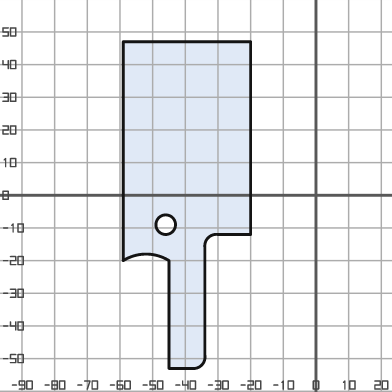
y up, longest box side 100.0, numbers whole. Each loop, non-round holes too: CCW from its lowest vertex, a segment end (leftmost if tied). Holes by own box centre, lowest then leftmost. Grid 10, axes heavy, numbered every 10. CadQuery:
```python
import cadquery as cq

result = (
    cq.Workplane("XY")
    .moveTo(-45.0, -53.0)
    .lineTo(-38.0, -53.0)
    .threePointArc((-35.0, -52.0), (-34.0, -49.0))
    .lineTo(-34.0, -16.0)
    .threePointArc((-33.0, -13.0), (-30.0, -12.0))
    .lineTo(-20.0, -12.0)
    .lineTo(-20.0, 47.0)
    .lineTo(-59.0, 47.0)
    .lineTo(-59.0, -20.0)
    .threePointArc((-52.0, -18.0), (-45.0, -20.0))
    .close()
    .moveTo(-46.0, -9.0)
    .circle(3.0)
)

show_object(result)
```